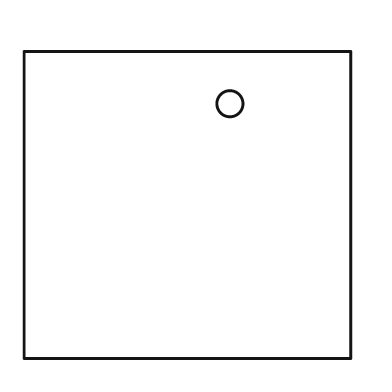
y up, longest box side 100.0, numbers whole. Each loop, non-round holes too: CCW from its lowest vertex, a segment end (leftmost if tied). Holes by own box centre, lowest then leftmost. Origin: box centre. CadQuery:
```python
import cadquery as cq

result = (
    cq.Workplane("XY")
    .moveTo(-50.0, -47.0)
    .lineTo(50.0, -47.0)
    .lineTo(50.0, 47.0)
    .lineTo(-50.0, 47.0)
    .close()
    .moveTo(13.0, 31.0)
    .circle(4.0)
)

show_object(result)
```